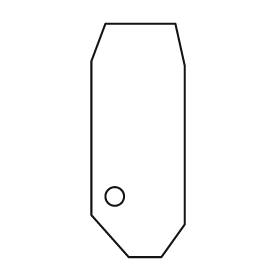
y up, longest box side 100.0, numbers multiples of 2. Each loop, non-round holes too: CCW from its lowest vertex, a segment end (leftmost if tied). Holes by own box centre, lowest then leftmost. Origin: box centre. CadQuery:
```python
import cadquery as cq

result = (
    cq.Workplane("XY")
    .moveTo(-4.0, -50.0)
    .lineTo(10.0, -50.0)
    .lineTo(20.0, -36.0)
    .lineTo(20.0, 32.0)
    .lineTo(16.0, 50.0)
    .lineTo(-14.0, 50.0)
    .lineTo(-20.0, 34.0)
    .lineTo(-20.0, -32.0)
    .close()
    .moveTo(-10.0, -24.0)
    .circle(4.0)
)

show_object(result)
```